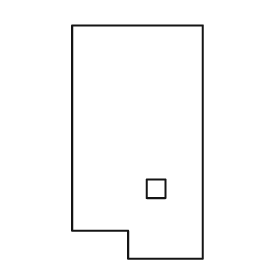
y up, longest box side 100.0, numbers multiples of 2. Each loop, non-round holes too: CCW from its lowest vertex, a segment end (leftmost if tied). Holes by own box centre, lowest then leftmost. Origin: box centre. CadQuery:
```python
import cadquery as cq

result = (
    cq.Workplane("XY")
    .moveTo(-4.0, -50.0)
    .lineTo(28.0, -50.0)
    .lineTo(28.0, 50.0)
    .lineTo(-28.0, 50.0)
    .lineTo(-28.0, -38.0)
    .lineTo(-4.0, -38.0)
    .close()
    .moveTo(4.0, -24.0)
    .lineTo(12.0, -24.0)
    .lineTo(12.0, -16.0)
    .lineTo(4.0, -16.0)
    .close()
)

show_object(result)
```